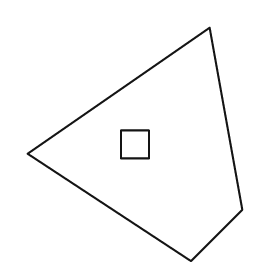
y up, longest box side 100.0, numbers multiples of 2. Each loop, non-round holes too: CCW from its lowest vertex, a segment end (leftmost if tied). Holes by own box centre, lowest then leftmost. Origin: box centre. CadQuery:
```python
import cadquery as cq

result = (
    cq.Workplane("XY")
    .moveTo(24.0, -50.0)
    .lineTo(46.0, -28.0)
    .lineTo(32.0, 50.0)
    .lineTo(-46.0, -4.0)
    .close()
    .moveTo(-6.0, -6.0)
    .lineTo(6.0, -6.0)
    .lineTo(6.0, 6.0)
    .lineTo(-6.0, 6.0)
    .close()
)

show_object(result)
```